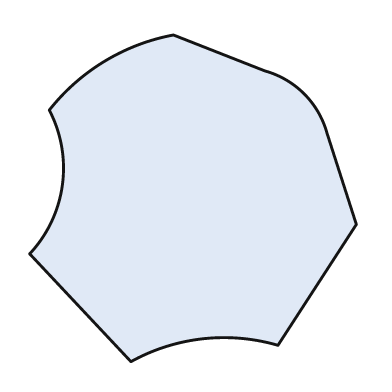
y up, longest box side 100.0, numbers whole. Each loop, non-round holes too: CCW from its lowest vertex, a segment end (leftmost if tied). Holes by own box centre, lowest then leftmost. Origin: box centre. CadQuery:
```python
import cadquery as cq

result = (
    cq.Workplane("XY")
    .moveTo(-19.0, -50.0)
    .threePointArc((3.0, -43.0), (26.0, -45.0))
    .lineTo(50.0, -8.0)
    .lineTo(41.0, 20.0)
    .threePointArc((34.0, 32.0), (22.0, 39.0))
    .lineTo(-6.0, 50.0)
    .threePointArc((-27.0, 42.0), (-44.0, 27.0))
    .threePointArc((-40.0, 4.0), (-50.0, -17.0))
    .close()
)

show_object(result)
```